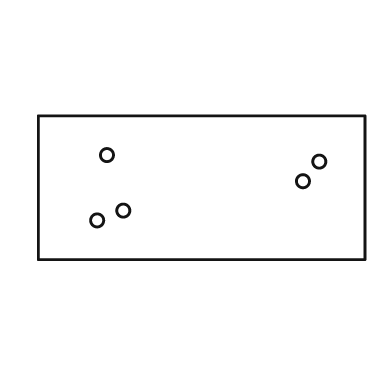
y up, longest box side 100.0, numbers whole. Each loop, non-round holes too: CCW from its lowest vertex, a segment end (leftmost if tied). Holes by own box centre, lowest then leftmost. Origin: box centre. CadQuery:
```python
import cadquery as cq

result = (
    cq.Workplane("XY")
    .moveTo(-50.0, -22.0)
    .lineTo(50.0, -22.0)
    .lineTo(50.0, 22.0)
    .lineTo(-50.0, 22.0)
    .close()
    .moveTo(-32.0, -10.0)
    .circle(2.0)
    .moveTo(-24.0, -7.0)
    .circle(2.0)
    .moveTo(31.0, 2.0)
    .circle(2.0)
    .moveTo(36.0, 8.0)
    .circle(2.0)
    .moveTo(-29.0, 10.0)
    .circle(2.0)
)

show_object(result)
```